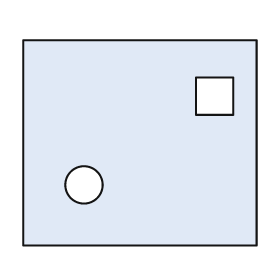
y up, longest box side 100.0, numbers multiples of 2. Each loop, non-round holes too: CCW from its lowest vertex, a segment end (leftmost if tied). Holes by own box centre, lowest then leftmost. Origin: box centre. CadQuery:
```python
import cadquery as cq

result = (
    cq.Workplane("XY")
    .moveTo(-50.0, -44.0)
    .lineTo(50.0, -44.0)
    .lineTo(50.0, 44.0)
    .lineTo(-50.0, 44.0)
    .close()
    .moveTo(-24.0, -18.0)
    .circle(8.0)
    .moveTo(24.0, 12.0)
    .lineTo(40.0, 12.0)
    .lineTo(40.0, 28.0)
    .lineTo(24.0, 28.0)
    .close()
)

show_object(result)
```